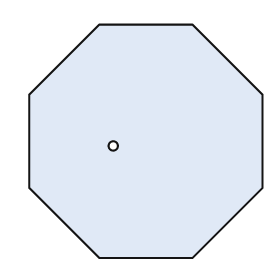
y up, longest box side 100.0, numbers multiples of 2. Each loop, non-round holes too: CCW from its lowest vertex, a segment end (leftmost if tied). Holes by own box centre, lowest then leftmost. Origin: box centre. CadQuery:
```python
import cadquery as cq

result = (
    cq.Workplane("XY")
    .moveTo(-20.0, -50.0)
    .lineTo(20.0, -50.0)
    .lineTo(50.0, -20.0)
    .lineTo(50.0, 20.0)
    .lineTo(20.0, 50.0)
    .lineTo(-20.0, 50.0)
    .lineTo(-50.0, 20.0)
    .lineTo(-50.0, -20.0)
    .close()
    .moveTo(-14.0, -2.0)
    .circle(2.0)
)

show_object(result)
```